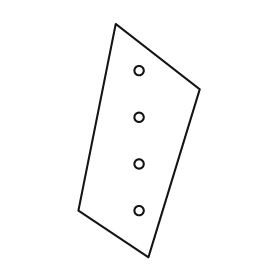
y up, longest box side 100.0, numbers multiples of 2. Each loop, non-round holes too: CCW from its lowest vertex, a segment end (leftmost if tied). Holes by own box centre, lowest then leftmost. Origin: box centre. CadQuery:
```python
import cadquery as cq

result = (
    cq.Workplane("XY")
    .moveTo(4.0, -50.0)
    .lineTo(26.0, 22.0)
    .lineTo(-10.0, 50.0)
    .lineTo(-26.0, -30.0)
    .close()
    .moveTo(0.0, -30.0)
    .circle(2.0)
    .moveTo(0.0, -10.0)
    .circle(2.0)
    .moveTo(0.0, 10.0)
    .circle(2.0)
    .moveTo(0.0, 30.0)
    .circle(2.0)
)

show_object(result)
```